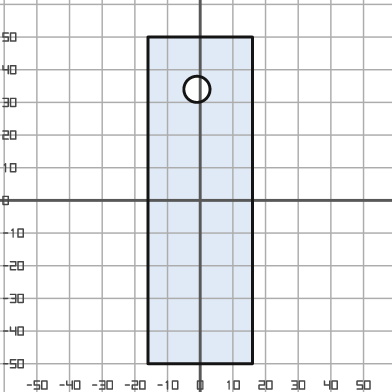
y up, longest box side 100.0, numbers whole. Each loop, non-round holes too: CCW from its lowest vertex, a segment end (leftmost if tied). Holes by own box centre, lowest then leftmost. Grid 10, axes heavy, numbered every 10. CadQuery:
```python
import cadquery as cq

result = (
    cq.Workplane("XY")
    .moveTo(-16.0, -50.0)
    .lineTo(16.0, -50.0)
    .lineTo(16.0, 50.0)
    .lineTo(-16.0, 50.0)
    .close()
    .moveTo(-1.0, 34.0)
    .circle(4.0)
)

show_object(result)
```